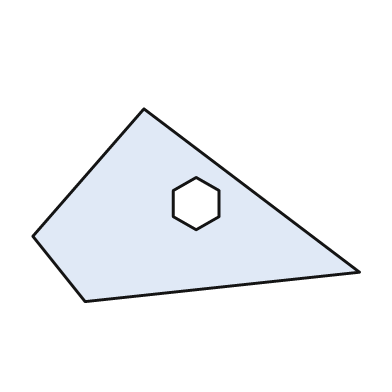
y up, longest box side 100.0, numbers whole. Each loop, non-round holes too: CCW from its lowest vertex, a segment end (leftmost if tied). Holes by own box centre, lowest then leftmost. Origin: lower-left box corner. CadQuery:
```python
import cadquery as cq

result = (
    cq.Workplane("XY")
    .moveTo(16.0, 0.0)
    .lineTo(100.0, 9.0)
    .lineTo(34.0, 59.0)
    .lineTo(0.0, 20.0)
    .close()
    .moveTo(50.0, 22.0)
    .lineTo(57.0, 26.0)
    .lineTo(57.0, 34.0)
    .lineTo(50.0, 38.0)
    .lineTo(43.0, 34.0)
    .lineTo(43.0, 26.0)
    .close()
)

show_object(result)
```